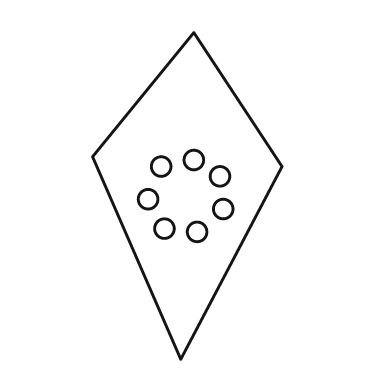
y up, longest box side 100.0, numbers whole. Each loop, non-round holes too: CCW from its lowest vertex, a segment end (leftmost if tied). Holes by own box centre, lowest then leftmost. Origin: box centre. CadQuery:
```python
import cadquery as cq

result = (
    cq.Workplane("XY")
    .moveTo(-2.0, -50.0)
    .lineTo(29.0, 9.0)
    .lineTo(2.0, 50.0)
    .lineTo(-29.0, 12.0)
    .close()
    .moveTo(3.0, -11.0)
    .circle(3.0)
    .moveTo(-7.0, -10.0)
    .circle(3.0)
    .moveTo(11.0, -4.0)
    .circle(3.0)
    .moveTo(-12.0, -1.0)
    .circle(3.0)
    .moveTo(10.0, 6.0)
    .circle(3.0)
    .moveTo(-8.0, 9.0)
    .circle(3.0)
    .moveTo(2.0, 11.0)
    .circle(3.0)
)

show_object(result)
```